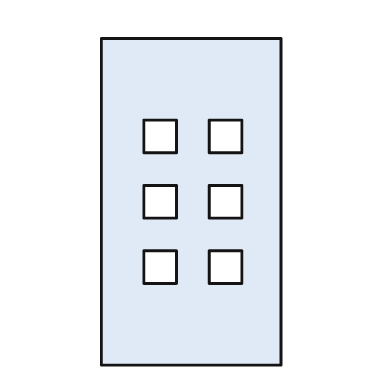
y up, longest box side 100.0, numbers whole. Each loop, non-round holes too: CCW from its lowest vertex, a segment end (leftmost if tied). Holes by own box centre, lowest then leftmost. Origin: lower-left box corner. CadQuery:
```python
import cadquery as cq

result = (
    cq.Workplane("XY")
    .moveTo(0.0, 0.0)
    .lineTo(55.0, 0.0)
    .lineTo(55.0, 100.0)
    .lineTo(0.0, 100.0)
    .close()
    .moveTo(13.0, 25.0)
    .lineTo(23.0, 25.0)
    .lineTo(23.0, 35.0)
    .lineTo(13.0, 35.0)
    .close()
    .moveTo(33.0, 25.0)
    .lineTo(43.0, 25.0)
    .lineTo(43.0, 35.0)
    .lineTo(33.0, 35.0)
    .close()
    .moveTo(13.0, 45.0)
    .lineTo(23.0, 45.0)
    .lineTo(23.0, 55.0)
    .lineTo(13.0, 55.0)
    .close()
    .moveTo(33.0, 45.0)
    .lineTo(43.0, 45.0)
    .lineTo(43.0, 55.0)
    .lineTo(33.0, 55.0)
    .close()
    .moveTo(13.0, 65.0)
    .lineTo(23.0, 65.0)
    .lineTo(23.0, 75.0)
    .lineTo(13.0, 75.0)
    .close()
    .moveTo(33.0, 65.0)
    .lineTo(43.0, 65.0)
    .lineTo(43.0, 75.0)
    .lineTo(33.0, 75.0)
    .close()
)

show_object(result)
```